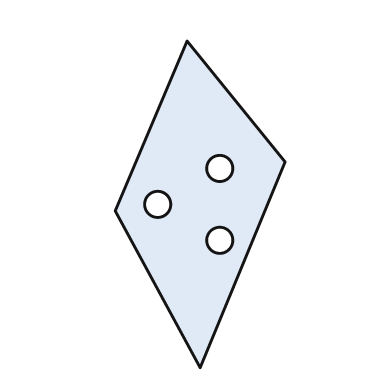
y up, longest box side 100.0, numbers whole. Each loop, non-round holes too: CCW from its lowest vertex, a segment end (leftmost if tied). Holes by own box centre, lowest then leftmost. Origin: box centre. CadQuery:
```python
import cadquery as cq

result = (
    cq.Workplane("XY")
    .moveTo(0.0, -50.0)
    .lineTo(26.0, 13.0)
    .lineTo(-4.0, 50.0)
    .lineTo(-26.0, -2.0)
    .close()
    .moveTo(6.0, -11.0)
    .circle(4.0)
    .moveTo(-13.0, 0.0)
    .circle(4.0)
    .moveTo(6.0, 11.0)
    .circle(4.0)
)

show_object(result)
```